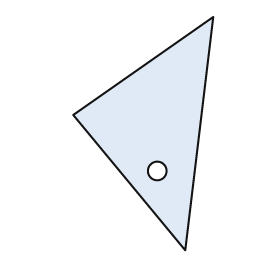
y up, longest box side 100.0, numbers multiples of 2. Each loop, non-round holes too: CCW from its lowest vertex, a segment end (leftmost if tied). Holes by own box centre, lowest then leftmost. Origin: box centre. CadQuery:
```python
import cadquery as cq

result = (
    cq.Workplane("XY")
    .moveTo(18.0, -50.0)
    .lineTo(30.0, 50.0)
    .lineTo(-30.0, 8.0)
    .close()
    .moveTo(6.0, -16.0)
    .circle(4.0)
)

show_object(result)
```